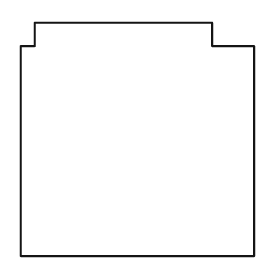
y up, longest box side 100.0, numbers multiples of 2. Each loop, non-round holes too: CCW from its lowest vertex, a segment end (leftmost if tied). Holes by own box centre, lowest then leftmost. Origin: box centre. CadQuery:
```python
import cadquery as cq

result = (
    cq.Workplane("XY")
    .moveTo(-50.0, -50.0)
    .lineTo(50.0, -50.0)
    .lineTo(50.0, 40.0)
    .lineTo(32.0, 40.0)
    .lineTo(32.0, 50.0)
    .lineTo(-44.0, 50.0)
    .lineTo(-44.0, 40.0)
    .lineTo(-50.0, 40.0)
    .close()
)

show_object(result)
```